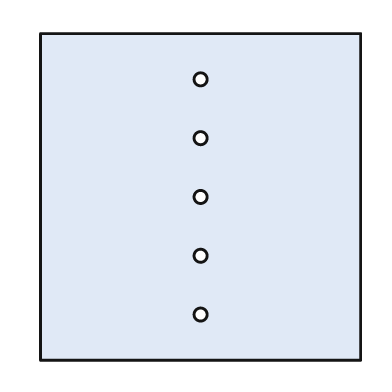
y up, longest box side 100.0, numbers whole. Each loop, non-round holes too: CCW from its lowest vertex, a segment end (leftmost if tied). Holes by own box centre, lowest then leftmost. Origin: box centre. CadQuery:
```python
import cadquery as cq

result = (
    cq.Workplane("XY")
    .moveTo(-49.0, -50.0)
    .lineTo(49.0, -50.0)
    .lineTo(49.0, 50.0)
    .lineTo(-49.0, 50.0)
    .close()
    .moveTo(0.0, -36.0)
    .circle(2.0)
    .moveTo(0.0, -18.0)
    .circle(2.0)
    .moveTo(0.0, 0.0)
    .circle(2.0)
    .moveTo(0.0, 18.0)
    .circle(2.0)
    .moveTo(0.0, 36.0)
    .circle(2.0)
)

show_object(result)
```